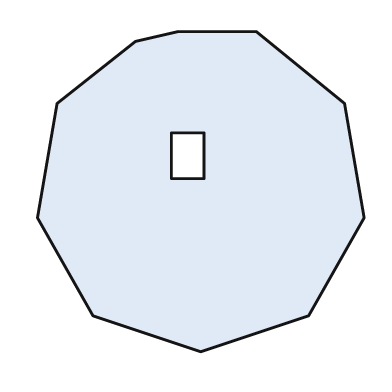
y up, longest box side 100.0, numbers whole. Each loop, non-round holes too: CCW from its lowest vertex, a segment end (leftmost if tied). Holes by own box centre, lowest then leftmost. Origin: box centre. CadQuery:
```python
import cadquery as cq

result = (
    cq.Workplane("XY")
    .moveTo(0.0, -49.0)
    .lineTo(33.0, -38.0)
    .lineTo(50.0, -8.0)
    .lineTo(44.0, 27.0)
    .lineTo(17.0, 49.0)
    .lineTo(-7.0, 49.0)
    .lineTo(-20.0, 46.0)
    .lineTo(-44.0, 27.0)
    .lineTo(-50.0, -8.0)
    .lineTo(-33.0, -38.0)
    .close()
    .moveTo(-9.0, 4.0)
    .lineTo(1.0, 4.0)
    .lineTo(1.0, 18.0)
    .lineTo(-9.0, 18.0)
    .close()
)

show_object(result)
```